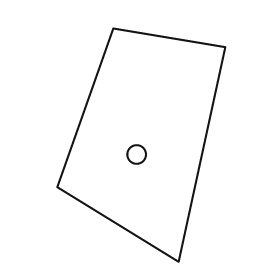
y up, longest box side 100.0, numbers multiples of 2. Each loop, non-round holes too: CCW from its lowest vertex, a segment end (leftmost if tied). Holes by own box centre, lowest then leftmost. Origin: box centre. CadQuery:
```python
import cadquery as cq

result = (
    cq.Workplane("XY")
    .moveTo(16.0, -50.0)
    .lineTo(36.0, 42.0)
    .lineTo(-12.0, 50.0)
    .lineTo(-36.0, -18.0)
    .close()
    .moveTo(-2.0, -4.0)
    .circle(4.0)
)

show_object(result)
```